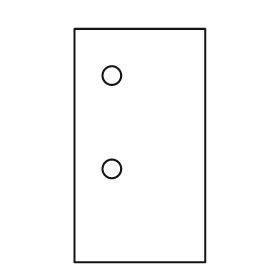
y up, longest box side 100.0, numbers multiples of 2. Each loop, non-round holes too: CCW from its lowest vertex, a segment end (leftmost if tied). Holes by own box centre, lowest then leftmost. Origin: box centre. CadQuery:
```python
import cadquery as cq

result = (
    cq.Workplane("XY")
    .moveTo(-28.0, -50.0)
    .lineTo(28.0, -50.0)
    .lineTo(28.0, 50.0)
    .lineTo(-28.0, 50.0)
    .close()
    .moveTo(-12.0, -10.0)
    .circle(4.0)
    .moveTo(-12.0, 30.0)
    .circle(4.0)
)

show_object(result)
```